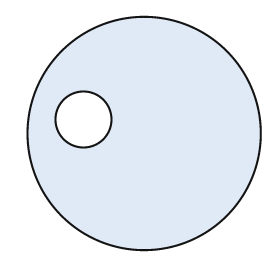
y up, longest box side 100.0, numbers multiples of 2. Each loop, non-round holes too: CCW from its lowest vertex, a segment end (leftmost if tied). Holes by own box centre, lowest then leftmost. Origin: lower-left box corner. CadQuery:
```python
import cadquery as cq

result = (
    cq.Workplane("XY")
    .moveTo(50.0, 50.0)
    .circle(50.0)
    .moveTo(24.0, 56.0)
    .circle(12.0)
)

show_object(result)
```